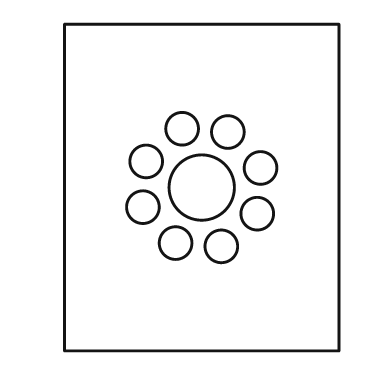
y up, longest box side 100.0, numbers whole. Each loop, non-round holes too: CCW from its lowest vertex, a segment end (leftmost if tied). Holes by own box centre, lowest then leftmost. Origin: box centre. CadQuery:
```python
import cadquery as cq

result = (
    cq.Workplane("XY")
    .moveTo(-42.0, -50.0)
    .lineTo(42.0, -50.0)
    .lineTo(42.0, 50.0)
    .lineTo(-42.0, 50.0)
    .close()
    .moveTo(6.0, -18.0)
    .circle(5.0)
    .moveTo(-8.0, -17.0)
    .circle(5.0)
    .moveTo(17.0, -8.0)
    .circle(5.0)
    .moveTo(-18.0, -6.0)
    .circle(5.0)
    .moveTo(0.0, 0.0)
    .circle(10.0)
    .moveTo(18.0, 6.0)
    .circle(5.0)
    .moveTo(-17.0, 8.0)
    .circle(5.0)
    .moveTo(8.0, 17.0)
    .circle(5.0)
    .moveTo(-6.0, 18.0)
    .circle(5.0)
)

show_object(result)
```